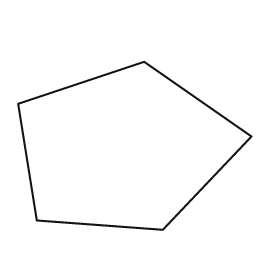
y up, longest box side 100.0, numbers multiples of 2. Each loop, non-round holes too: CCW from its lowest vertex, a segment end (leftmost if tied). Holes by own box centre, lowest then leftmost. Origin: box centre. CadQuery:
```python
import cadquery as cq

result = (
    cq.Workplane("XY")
    .moveTo(12.0, -36.0)
    .lineTo(50.0, 4.0)
    .lineTo(4.0, 36.0)
    .lineTo(-50.0, 18.0)
    .lineTo(-42.0, -32.0)
    .close()
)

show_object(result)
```